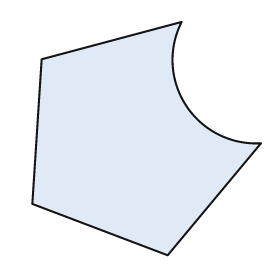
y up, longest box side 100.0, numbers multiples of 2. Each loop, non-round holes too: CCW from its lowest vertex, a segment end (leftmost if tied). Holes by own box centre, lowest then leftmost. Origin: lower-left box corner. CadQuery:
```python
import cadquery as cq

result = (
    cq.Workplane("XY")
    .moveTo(58.0, 0.0)
    .lineTo(98.0, 48.0)
    .threePointArc((66.0, 64.0), (64.0, 100.0))
    .lineTo(4.0, 84.0)
    .lineTo(0.0, 22.0)
    .close()
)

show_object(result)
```